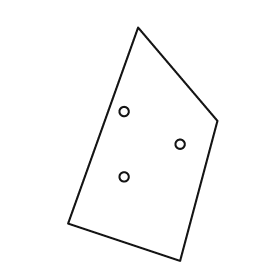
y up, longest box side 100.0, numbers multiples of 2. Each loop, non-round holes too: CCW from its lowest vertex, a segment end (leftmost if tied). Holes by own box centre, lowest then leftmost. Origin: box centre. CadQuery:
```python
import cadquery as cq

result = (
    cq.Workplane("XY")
    .moveTo(16.0, -50.0)
    .lineTo(32.0, 10.0)
    .lineTo(-2.0, 50.0)
    .lineTo(-32.0, -34.0)
    .close()
    .moveTo(-8.0, -14.0)
    .circle(2.0)
    .moveTo(16.0, 0.0)
    .circle(2.0)
    .moveTo(-8.0, 14.0)
    .circle(2.0)
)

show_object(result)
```